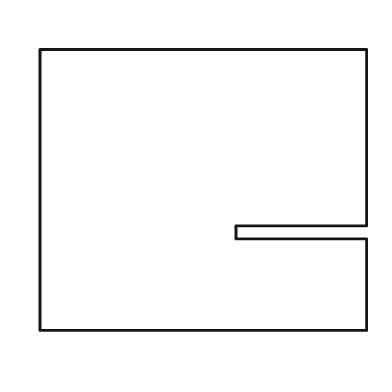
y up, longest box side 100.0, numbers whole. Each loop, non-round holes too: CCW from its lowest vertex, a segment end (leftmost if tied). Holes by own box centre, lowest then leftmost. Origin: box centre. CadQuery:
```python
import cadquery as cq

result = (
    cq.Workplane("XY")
    .moveTo(-50.0, -43.0)
    .lineTo(50.0, -43.0)
    .lineTo(50.0, -15.0)
    .lineTo(10.0, -15.0)
    .lineTo(10.0, -11.0)
    .lineTo(50.0, -11.0)
    .lineTo(50.0, 43.0)
    .lineTo(-50.0, 43.0)
    .close()
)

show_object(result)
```